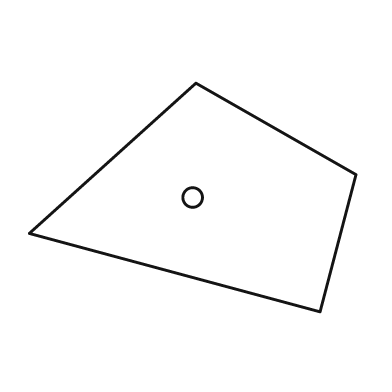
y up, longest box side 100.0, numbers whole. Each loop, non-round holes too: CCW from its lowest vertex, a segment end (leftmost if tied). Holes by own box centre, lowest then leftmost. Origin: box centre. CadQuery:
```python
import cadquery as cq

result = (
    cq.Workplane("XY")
    .moveTo(39.0, -35.0)
    .lineTo(50.0, 7.0)
    .lineTo(1.0, 35.0)
    .lineTo(-50.0, -11.0)
    .close()
    .moveTo(0.0, 0.0)
    .circle(3.0)
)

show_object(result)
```